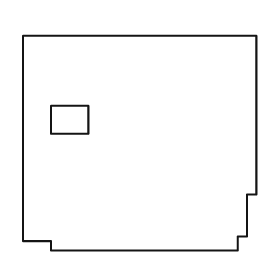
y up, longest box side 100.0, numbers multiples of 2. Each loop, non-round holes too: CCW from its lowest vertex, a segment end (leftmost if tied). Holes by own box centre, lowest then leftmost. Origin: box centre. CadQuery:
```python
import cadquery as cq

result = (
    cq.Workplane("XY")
    .moveTo(-38.0, -46.0)
    .lineTo(42.0, -46.0)
    .lineTo(42.0, -40.0)
    .lineTo(46.0, -40.0)
    .lineTo(46.0, -22.0)
    .lineTo(50.0, -22.0)
    .lineTo(50.0, 46.0)
    .lineTo(-50.0, 46.0)
    .lineTo(-50.0, -42.0)
    .lineTo(-38.0, -42.0)
    .close()
    .moveTo(-38.0, 4.0)
    .lineTo(-22.0, 4.0)
    .lineTo(-22.0, 16.0)
    .lineTo(-38.0, 16.0)
    .close()
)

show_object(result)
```